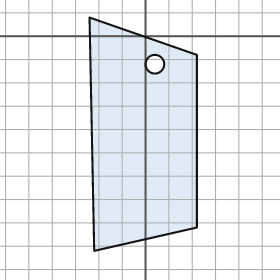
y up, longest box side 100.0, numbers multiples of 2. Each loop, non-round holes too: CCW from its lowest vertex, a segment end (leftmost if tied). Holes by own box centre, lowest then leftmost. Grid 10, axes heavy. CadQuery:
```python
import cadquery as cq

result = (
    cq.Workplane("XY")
    .moveTo(-22.0, -92.0)
    .lineTo(22.0, -82.0)
    .lineTo(22.0, -8.0)
    .lineTo(-24.0, 8.0)
    .close()
    .moveTo(4.0, -12.0)
    .circle(4.0)
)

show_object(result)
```